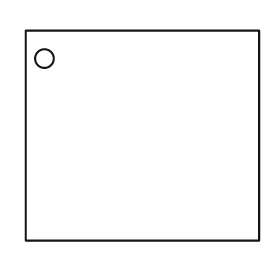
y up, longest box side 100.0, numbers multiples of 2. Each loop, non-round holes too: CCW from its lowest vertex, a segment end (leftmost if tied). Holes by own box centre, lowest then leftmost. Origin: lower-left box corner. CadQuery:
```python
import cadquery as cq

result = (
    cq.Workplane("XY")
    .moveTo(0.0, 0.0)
    .lineTo(100.0, 0.0)
    .lineTo(100.0, 90.0)
    .lineTo(0.0, 90.0)
    .close()
    .moveTo(8.0, 78.0)
    .circle(4.0)
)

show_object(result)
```